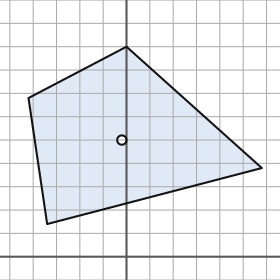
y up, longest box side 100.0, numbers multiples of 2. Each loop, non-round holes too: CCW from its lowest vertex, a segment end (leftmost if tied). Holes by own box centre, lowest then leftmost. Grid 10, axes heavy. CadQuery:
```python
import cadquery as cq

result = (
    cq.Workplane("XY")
    .moveTo(-34.0, 14.0)
    .lineTo(58.0, 38.0)
    .lineTo(0.0, 90.0)
    .lineTo(-42.0, 68.0)
    .close()
    .moveTo(-2.0, 50.0)
    .circle(2.0)
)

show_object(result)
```